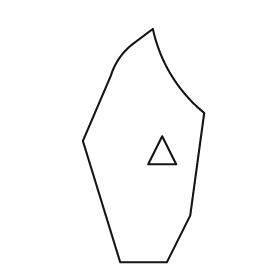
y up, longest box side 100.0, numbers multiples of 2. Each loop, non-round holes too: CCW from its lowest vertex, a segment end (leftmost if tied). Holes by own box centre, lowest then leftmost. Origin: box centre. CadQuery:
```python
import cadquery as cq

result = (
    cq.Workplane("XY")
    .moveTo(-10.0, -50.0)
    .lineTo(10.0, -50.0)
    .lineTo(20.0, -30.0)
    .lineTo(26.0, 14.0)
    .threePointArc((12.0, 30.0), (4.0, 50.0))
    .lineTo(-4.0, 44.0)
    .threePointArc((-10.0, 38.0), (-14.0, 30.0))
    .lineTo(-26.0, 2.0)
    .close()
    .moveTo(2.0, -8.0)
    .lineTo(14.0, -8.0)
    .lineTo(8.0, 4.0)
    .close()
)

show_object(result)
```